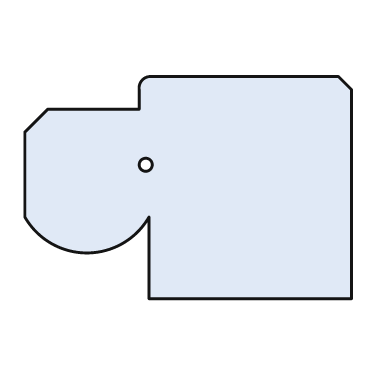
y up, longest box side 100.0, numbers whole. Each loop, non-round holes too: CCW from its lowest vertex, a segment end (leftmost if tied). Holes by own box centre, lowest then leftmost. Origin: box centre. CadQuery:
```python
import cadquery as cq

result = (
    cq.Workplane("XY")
    .moveTo(-12.0, -34.0)
    .lineTo(50.0, -34.0)
    .lineTo(50.0, 30.0)
    .lineTo(46.0, 34.0)
    .lineTo(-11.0, 34.0)
    .threePointArc((-14.0, 33.0), (-15.0, 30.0))
    .lineTo(-15.0, 24.0)
    .lineTo(-43.0, 24.0)
    .lineTo(-50.0, 17.0)
    .lineTo(-50.0, -9.0)
    .threePointArc((-31.0, -20.0), (-12.0, -9.0))
    .close()
    .moveTo(-13.0, 7.0)
    .circle(2.0)
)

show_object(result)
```